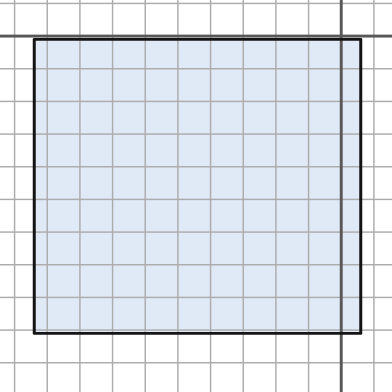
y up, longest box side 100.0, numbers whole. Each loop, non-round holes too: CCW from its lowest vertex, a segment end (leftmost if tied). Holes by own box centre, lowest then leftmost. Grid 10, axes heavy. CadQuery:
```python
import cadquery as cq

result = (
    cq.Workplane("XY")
    .moveTo(-94.0, -91.0)
    .lineTo(6.0, -91.0)
    .lineTo(6.0, -1.0)
    .lineTo(-94.0, -1.0)
    .close()
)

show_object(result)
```